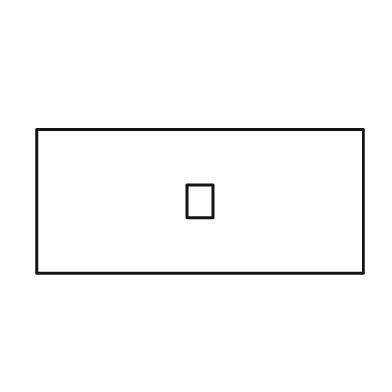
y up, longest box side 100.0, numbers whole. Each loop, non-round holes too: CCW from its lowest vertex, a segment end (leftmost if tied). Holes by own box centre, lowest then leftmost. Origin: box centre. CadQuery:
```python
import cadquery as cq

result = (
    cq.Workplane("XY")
    .moveTo(-50.0, -22.0)
    .lineTo(50.0, -22.0)
    .lineTo(50.0, 22.0)
    .lineTo(-50.0, 22.0)
    .close()
    .moveTo(-4.0, -5.0)
    .lineTo(4.0, -5.0)
    .lineTo(4.0, 5.0)
    .lineTo(-4.0, 5.0)
    .close()
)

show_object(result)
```